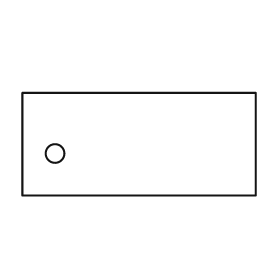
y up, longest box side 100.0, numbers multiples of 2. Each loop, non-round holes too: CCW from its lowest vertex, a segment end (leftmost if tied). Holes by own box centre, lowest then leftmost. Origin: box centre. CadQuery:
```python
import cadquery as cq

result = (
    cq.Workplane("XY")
    .moveTo(-50.0, -22.0)
    .lineTo(50.0, -22.0)
    .lineTo(50.0, 22.0)
    .lineTo(-50.0, 22.0)
    .close()
    .moveTo(-36.0, -4.0)
    .circle(4.0)
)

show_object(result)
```